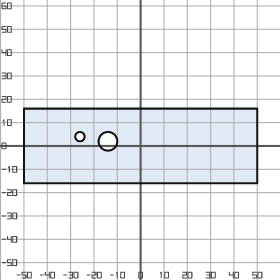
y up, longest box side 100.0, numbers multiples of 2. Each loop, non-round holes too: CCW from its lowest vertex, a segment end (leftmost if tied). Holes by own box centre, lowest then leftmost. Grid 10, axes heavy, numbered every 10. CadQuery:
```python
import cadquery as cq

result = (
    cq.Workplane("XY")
    .moveTo(-50.0, -16.0)
    .lineTo(50.0, -16.0)
    .lineTo(50.0, 16.0)
    .lineTo(-50.0, 16.0)
    .close()
    .moveTo(-14.0, 2.0)
    .circle(4.0)
    .moveTo(-26.0, 4.0)
    .circle(2.0)
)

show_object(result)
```